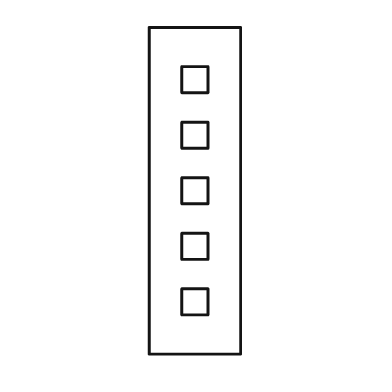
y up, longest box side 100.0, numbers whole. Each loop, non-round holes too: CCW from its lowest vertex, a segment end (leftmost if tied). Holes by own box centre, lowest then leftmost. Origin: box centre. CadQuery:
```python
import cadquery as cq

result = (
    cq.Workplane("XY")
    .moveTo(-14.0, -50.0)
    .lineTo(14.0, -50.0)
    .lineTo(14.0, 50.0)
    .lineTo(-14.0, 50.0)
    .close()
    .moveTo(-4.0, -38.0)
    .lineTo(4.0, -38.0)
    .lineTo(4.0, -30.0)
    .lineTo(-4.0, -30.0)
    .close()
    .moveTo(-4.0, -21.0)
    .lineTo(4.0, -21.0)
    .lineTo(4.0, -13.0)
    .lineTo(-4.0, -13.0)
    .close()
    .moveTo(-4.0, -4.0)
    .lineTo(4.0, -4.0)
    .lineTo(4.0, 4.0)
    .lineTo(-4.0, 4.0)
    .close()
    .moveTo(-4.0, 13.0)
    .lineTo(4.0, 13.0)
    .lineTo(4.0, 21.0)
    .lineTo(-4.0, 21.0)
    .close()
    .moveTo(-4.0, 30.0)
    .lineTo(4.0, 30.0)
    .lineTo(4.0, 38.0)
    .lineTo(-4.0, 38.0)
    .close()
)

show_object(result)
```